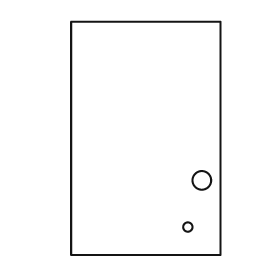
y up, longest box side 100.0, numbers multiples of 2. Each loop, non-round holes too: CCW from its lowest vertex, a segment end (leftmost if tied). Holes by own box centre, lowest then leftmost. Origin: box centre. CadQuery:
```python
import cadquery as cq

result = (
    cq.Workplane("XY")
    .moveTo(-32.0, -50.0)
    .lineTo(32.0, -50.0)
    .lineTo(32.0, 50.0)
    .lineTo(-32.0, 50.0)
    .close()
    .moveTo(18.0, -38.0)
    .circle(2.0)
    .moveTo(24.0, -18.0)
    .circle(4.0)
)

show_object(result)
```